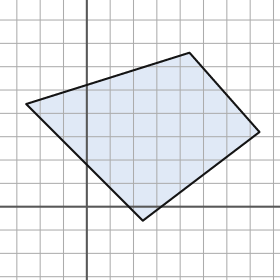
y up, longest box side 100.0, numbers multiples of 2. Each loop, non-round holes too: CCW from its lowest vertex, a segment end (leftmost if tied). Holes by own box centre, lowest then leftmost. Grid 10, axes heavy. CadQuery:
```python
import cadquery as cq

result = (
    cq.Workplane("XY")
    .moveTo(24.0, -6.0)
    .lineTo(74.0, 32.0)
    .lineTo(44.0, 66.0)
    .lineTo(-26.0, 44.0)
    .close()
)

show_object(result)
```